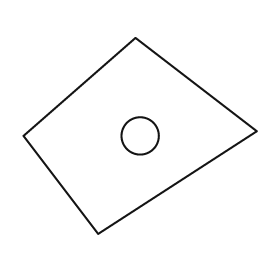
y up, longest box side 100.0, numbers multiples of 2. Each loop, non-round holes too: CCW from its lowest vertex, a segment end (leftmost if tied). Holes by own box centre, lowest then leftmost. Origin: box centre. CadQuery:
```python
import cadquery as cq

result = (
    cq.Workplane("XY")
    .moveTo(-18.0, -42.0)
    .lineTo(50.0, 2.0)
    .lineTo(-2.0, 42.0)
    .lineTo(-50.0, 0.0)
    .close()
    .moveTo(0.0, 0.0)
    .circle(8.0)
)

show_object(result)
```